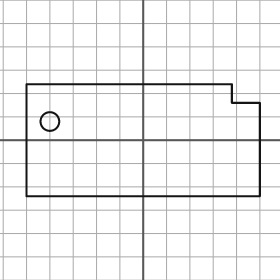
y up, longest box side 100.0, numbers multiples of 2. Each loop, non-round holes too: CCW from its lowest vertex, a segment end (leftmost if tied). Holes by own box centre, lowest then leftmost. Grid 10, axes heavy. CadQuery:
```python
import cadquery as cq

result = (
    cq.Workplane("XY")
    .moveTo(-50.0, -24.0)
    .lineTo(50.0, -24.0)
    .lineTo(50.0, 16.0)
    .lineTo(38.0, 16.0)
    .lineTo(38.0, 24.0)
    .lineTo(-50.0, 24.0)
    .close()
    .moveTo(-40.0, 8.0)
    .circle(4.0)
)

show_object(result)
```